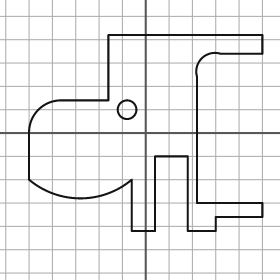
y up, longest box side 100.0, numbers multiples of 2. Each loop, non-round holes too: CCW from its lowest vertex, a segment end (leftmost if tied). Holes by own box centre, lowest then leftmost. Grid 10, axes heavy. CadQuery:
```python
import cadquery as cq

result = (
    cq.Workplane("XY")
    .moveTo(-6.0, -42.0)
    .lineTo(4.0, -42.0)
    .lineTo(4.0, -10.0)
    .lineTo(18.0, -10.0)
    .lineTo(18.0, -42.0)
    .lineTo(30.0, -42.0)
    .lineTo(30.0, -36.0)
    .lineTo(50.0, -36.0)
    .lineTo(50.0, -30.0)
    .lineTo(22.0, -30.0)
    .lineTo(22.0, 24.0)
    .threePointArc((24.0, 32.0), (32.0, 34.0))
    .lineTo(50.0, 34.0)
    .lineTo(50.0, 42.0)
    .lineTo(-16.0, 42.0)
    .lineTo(-16.0, 14.0)
    .lineTo(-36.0, 14.0)
    .threePointArc((-46.0, 10.0), (-50.0, 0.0))
    .lineTo(-50.0, -20.0)
    .threePointArc((-28.0, -28.0), (-6.0, -20.0))
    .close()
    .moveTo(-8.0, 10.0)
    .circle(4.0)
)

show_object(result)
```